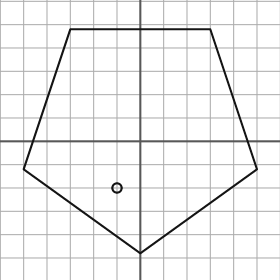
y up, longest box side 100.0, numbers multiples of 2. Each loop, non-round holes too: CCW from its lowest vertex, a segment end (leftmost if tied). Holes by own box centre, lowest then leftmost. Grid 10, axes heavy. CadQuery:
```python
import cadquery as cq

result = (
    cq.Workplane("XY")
    .moveTo(0.0, -48.0)
    .lineTo(50.0, -12.0)
    .lineTo(30.0, 48.0)
    .lineTo(-30.0, 48.0)
    .lineTo(-50.0, -12.0)
    .close()
    .moveTo(-10.0, -20.0)
    .circle(2.0)
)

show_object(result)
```